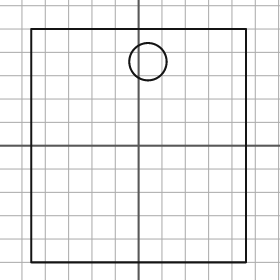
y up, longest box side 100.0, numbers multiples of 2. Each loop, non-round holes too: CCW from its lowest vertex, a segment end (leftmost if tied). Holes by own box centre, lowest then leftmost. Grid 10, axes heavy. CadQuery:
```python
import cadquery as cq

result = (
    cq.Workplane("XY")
    .moveTo(-46.0, -50.0)
    .lineTo(46.0, -50.0)
    .lineTo(46.0, 50.0)
    .lineTo(-46.0, 50.0)
    .close()
    .moveTo(4.0, 36.0)
    .circle(8.0)
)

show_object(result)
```